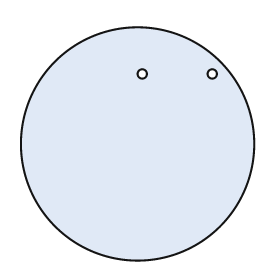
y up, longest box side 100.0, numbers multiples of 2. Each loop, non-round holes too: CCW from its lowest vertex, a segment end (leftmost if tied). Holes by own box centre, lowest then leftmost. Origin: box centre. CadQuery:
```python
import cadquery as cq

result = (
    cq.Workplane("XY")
    .moveTo(0.0, 0.0)
    .circle(50.0)
    .moveTo(2.0, 30.0)
    .circle(2.0)
    .moveTo(32.0, 30.0)
    .circle(2.0)
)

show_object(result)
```